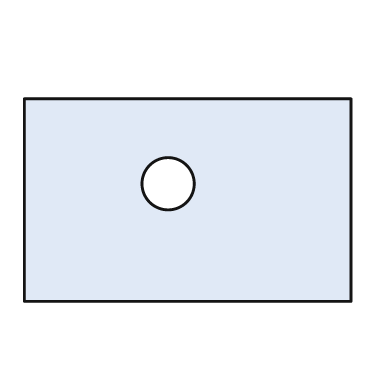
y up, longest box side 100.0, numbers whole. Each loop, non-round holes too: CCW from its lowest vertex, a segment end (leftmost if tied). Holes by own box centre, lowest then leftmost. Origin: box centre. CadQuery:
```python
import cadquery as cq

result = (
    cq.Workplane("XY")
    .moveTo(-50.0, -31.0)
    .lineTo(50.0, -31.0)
    .lineTo(50.0, 31.0)
    .lineTo(-50.0, 31.0)
    .close()
    .moveTo(-6.0, 5.0)
    .circle(8.0)
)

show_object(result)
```